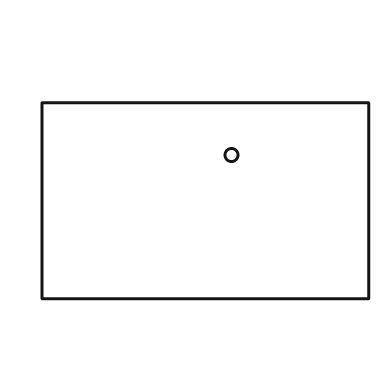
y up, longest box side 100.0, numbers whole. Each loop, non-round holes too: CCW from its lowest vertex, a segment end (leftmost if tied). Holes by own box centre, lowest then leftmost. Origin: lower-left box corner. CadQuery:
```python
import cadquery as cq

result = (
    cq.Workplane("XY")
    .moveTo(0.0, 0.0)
    .lineTo(100.0, 0.0)
    .lineTo(100.0, 60.0)
    .lineTo(0.0, 60.0)
    .close()
    .moveTo(58.0, 44.0)
    .circle(2.0)
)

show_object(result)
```